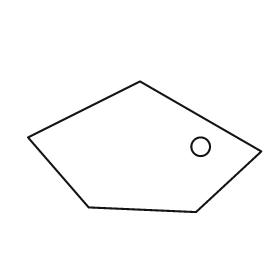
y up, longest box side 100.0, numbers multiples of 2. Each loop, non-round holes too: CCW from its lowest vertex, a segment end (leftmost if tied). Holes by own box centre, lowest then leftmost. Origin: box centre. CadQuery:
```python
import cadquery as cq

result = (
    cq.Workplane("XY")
    .moveTo(22.0, -28.0)
    .lineTo(50.0, -2.0)
    .lineTo(-2.0, 28.0)
    .lineTo(-50.0, 4.0)
    .lineTo(-24.0, -26.0)
    .close()
    .moveTo(24.0, 0.0)
    .circle(4.0)
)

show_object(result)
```